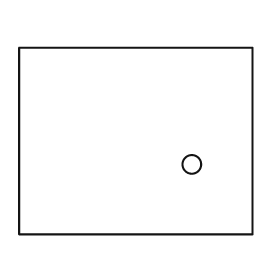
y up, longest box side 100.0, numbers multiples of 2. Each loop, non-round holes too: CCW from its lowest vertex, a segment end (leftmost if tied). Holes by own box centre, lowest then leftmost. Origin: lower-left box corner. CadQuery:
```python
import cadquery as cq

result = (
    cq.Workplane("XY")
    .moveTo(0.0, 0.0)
    .lineTo(100.0, 0.0)
    .lineTo(100.0, 80.0)
    .lineTo(0.0, 80.0)
    .close()
    .moveTo(74.0, 30.0)
    .circle(4.0)
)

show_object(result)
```